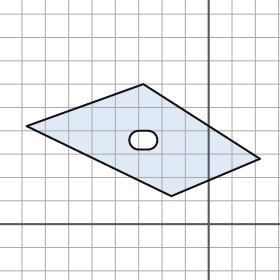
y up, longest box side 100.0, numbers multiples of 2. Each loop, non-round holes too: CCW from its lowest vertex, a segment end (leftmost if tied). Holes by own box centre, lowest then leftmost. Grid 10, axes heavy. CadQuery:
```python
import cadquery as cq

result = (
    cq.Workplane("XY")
    .moveTo(-16.0, 12.0)
    .lineTo(22.0, 28.0)
    .lineTo(-28.0, 60.0)
    .lineTo(-78.0, 42.0)
    .close()
    .moveTo(-30.0, 32.0)
    .lineTo(-26.0, 32.0)
    .threePointArc((-22.0, 36.0), (-26.0, 40.0))
    .lineTo(-30.0, 40.0)
    .threePointArc((-34.0, 36.0), (-30.0, 32.0))
    .close()
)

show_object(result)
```